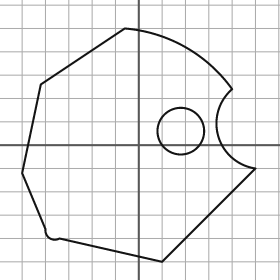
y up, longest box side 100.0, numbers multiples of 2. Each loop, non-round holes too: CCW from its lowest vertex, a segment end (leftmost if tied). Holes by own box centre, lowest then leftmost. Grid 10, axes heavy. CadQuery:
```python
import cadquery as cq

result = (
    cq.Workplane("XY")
    .moveTo(10.0, -50.0)
    .lineTo(50.0, -10.0)
    .threePointArc((34.0, 4.0), (40.0, 24.0))
    .threePointArc((20.0, 42.0), (-6.0, 50.0))
    .lineTo(-42.0, 26.0)
    .lineTo(-50.0, -12.0)
    .lineTo(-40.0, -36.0)
    .threePointArc((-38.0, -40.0), (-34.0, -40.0))
    .close()
    .moveTo(18.0, 6.0)
    .circle(10.0)
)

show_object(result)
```